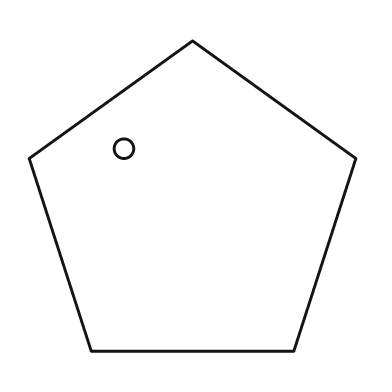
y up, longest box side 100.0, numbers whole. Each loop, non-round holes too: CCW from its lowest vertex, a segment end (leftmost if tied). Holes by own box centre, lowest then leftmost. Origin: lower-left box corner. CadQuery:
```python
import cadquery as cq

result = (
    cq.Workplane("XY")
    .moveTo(19.0, 0.0)
    .lineTo(81.0, 0.0)
    .lineTo(100.0, 59.0)
    .lineTo(50.0, 95.0)
    .lineTo(0.0, 59.0)
    .close()
    .moveTo(29.0, 62.0)
    .circle(3.0)
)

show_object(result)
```